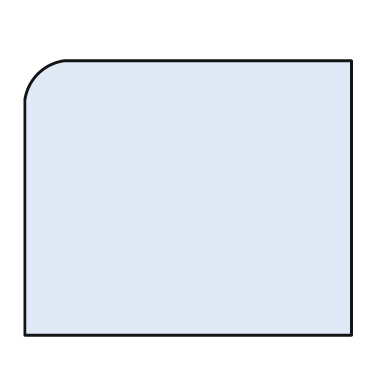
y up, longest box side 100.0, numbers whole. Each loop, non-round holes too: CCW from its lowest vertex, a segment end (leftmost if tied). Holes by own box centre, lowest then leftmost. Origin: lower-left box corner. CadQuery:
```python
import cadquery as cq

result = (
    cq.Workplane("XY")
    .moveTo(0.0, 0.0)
    .lineTo(100.0, 0.0)
    .lineTo(100.0, 84.0)
    .lineTo(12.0, 84.0)
    .threePointArc((4.0, 80.0), (0.0, 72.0))
    .close()
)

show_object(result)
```